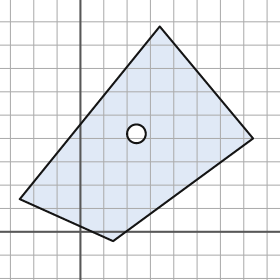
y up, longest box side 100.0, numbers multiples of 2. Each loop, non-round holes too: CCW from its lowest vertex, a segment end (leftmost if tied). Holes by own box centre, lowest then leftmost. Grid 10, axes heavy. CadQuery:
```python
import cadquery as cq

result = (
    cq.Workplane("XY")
    .moveTo(14.0, -4.0)
    .lineTo(74.0, 40.0)
    .lineTo(34.0, 88.0)
    .lineTo(-26.0, 14.0)
    .close()
    .moveTo(24.0, 42.0)
    .circle(4.0)
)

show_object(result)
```